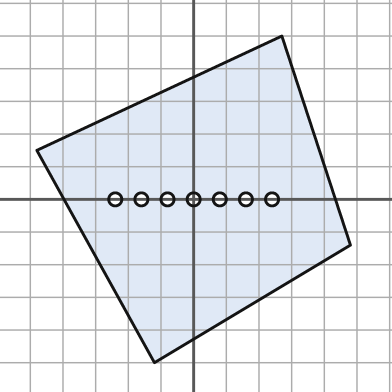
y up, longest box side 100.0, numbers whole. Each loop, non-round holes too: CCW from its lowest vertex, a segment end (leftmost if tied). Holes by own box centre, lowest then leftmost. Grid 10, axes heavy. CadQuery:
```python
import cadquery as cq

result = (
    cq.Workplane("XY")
    .moveTo(-12.0, -50.0)
    .lineTo(48.0, -14.0)
    .lineTo(27.0, 50.0)
    .lineTo(-48.0, 15.0)
    .close()
    .moveTo(-24.0, 0.0)
    .circle(2.0)
    .moveTo(-16.0, 0.0)
    .circle(2.0)
    .moveTo(-8.0, 0.0)
    .circle(2.0)
    .moveTo(0.0, 0.0)
    .circle(2.0)
    .moveTo(8.0, 0.0)
    .circle(2.0)
    .moveTo(16.0, 0.0)
    .circle(2.0)
    .moveTo(24.0, 0.0)
    .circle(2.0)
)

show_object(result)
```